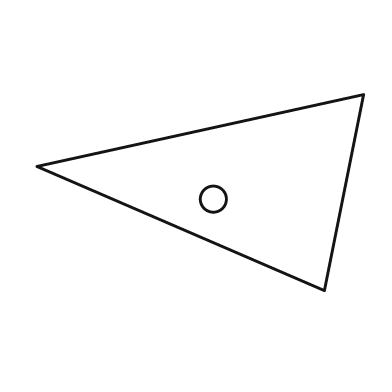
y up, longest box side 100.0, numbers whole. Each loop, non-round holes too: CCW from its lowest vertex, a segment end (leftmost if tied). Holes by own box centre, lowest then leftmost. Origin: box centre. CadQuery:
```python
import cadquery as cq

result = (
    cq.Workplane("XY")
    .moveTo(38.0, -30.0)
    .lineTo(50.0, 30.0)
    .lineTo(-50.0, 8.0)
    .close()
    .moveTo(4.0, -2.0)
    .circle(4.0)
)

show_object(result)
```